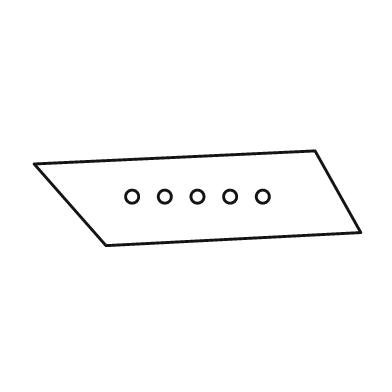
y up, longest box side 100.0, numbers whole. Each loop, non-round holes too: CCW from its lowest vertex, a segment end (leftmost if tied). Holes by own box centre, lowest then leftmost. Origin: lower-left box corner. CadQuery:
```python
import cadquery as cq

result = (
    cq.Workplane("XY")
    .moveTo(22.0, 0.0)
    .lineTo(100.0, 4.0)
    .lineTo(86.0, 29.0)
    .lineTo(0.0, 25.0)
    .close()
    .moveTo(30.0, 15.0)
    .circle(2.0)
    .moveTo(40.0, 15.0)
    .circle(2.0)
    .moveTo(50.0, 15.0)
    .circle(2.0)
    .moveTo(60.0, 15.0)
    .circle(2.0)
    .moveTo(70.0, 15.0)
    .circle(2.0)
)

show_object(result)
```